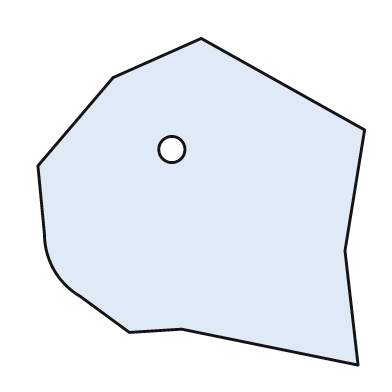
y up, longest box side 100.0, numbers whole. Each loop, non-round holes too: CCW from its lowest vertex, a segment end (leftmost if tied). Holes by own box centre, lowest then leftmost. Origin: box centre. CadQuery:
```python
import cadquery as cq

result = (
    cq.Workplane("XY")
    .moveTo(48.0, -50.0)
    .lineTo(44.0, -15.0)
    .lineTo(50.0, 22.0)
    .lineTo(0.0, 50.0)
    .lineTo(-27.0, 38.0)
    .lineTo(-50.0, 11.0)
    .lineTo(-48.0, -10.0)
    .threePointArc((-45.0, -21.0), (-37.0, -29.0))
    .lineTo(-22.0, -40.0)
    .lineTo(-6.0, -39.0)
    .close()
    .moveTo(-9.0, 16.0)
    .circle(4.0)
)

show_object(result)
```